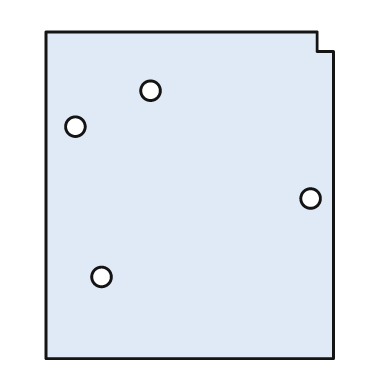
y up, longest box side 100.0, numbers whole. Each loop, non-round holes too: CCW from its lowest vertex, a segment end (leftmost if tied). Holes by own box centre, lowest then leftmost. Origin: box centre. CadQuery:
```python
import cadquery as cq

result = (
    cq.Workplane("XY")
    .moveTo(-44.0, -50.0)
    .lineTo(44.0, -50.0)
    .lineTo(44.0, 44.0)
    .lineTo(39.0, 44.0)
    .lineTo(39.0, 50.0)
    .lineTo(-44.0, 50.0)
    .close()
    .moveTo(-27.0, -25.0)
    .circle(3.0)
    .moveTo(37.0, -1.0)
    .circle(3.0)
    .moveTo(-35.0, 21.0)
    .circle(3.0)
    .moveTo(-12.0, 32.0)
    .circle(3.0)
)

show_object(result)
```